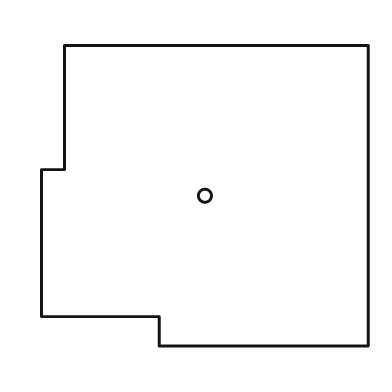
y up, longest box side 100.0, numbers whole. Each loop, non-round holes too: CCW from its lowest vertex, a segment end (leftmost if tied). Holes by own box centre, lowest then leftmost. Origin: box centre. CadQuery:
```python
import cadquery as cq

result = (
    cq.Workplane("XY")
    .moveTo(-14.0, -46.0)
    .lineTo(50.0, -46.0)
    .lineTo(50.0, 46.0)
    .lineTo(-43.0, 46.0)
    .lineTo(-43.0, 8.0)
    .lineTo(-50.0, 8.0)
    .lineTo(-50.0, -37.0)
    .lineTo(-14.0, -37.0)
    .close()
    .moveTo(0.0, 0.0)
    .circle(2.0)
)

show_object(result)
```